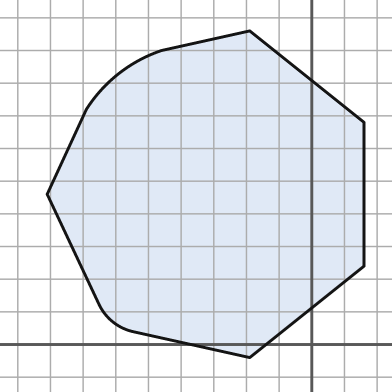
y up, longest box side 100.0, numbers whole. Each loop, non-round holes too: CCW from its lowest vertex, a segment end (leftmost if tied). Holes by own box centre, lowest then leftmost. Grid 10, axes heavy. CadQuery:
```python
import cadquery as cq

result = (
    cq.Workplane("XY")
    .moveTo(-19.0, -4.0)
    .lineTo(16.0, 24.0)
    .lineTo(16.0, 68.0)
    .lineTo(-19.0, 96.0)
    .lineTo(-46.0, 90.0)
    .threePointArc((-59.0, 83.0), (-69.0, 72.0))
    .lineTo(-81.0, 46.0)
    .lineTo(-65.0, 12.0)
    .threePointArc((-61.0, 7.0), (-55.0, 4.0))
    .close()
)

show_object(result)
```